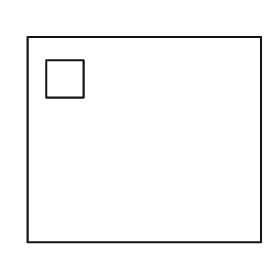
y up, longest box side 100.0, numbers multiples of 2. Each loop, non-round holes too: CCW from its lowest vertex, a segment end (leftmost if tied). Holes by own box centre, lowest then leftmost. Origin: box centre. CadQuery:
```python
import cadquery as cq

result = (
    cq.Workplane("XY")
    .moveTo(-50.0, -44.0)
    .lineTo(50.0, -44.0)
    .lineTo(50.0, 44.0)
    .lineTo(-50.0, 44.0)
    .close()
    .moveTo(-42.0, 18.0)
    .lineTo(-26.0, 18.0)
    .lineTo(-26.0, 34.0)
    .lineTo(-42.0, 34.0)
    .close()
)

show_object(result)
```